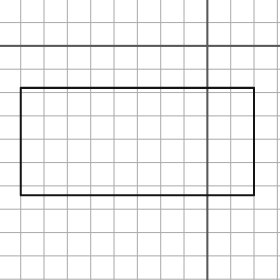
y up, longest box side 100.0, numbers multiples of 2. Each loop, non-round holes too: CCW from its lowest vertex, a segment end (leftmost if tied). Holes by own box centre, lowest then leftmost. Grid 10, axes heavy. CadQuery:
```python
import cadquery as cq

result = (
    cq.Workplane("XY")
    .moveTo(-80.0, -64.0)
    .lineTo(20.0, -64.0)
    .lineTo(20.0, -18.0)
    .lineTo(-80.0, -18.0)
    .close()
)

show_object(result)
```